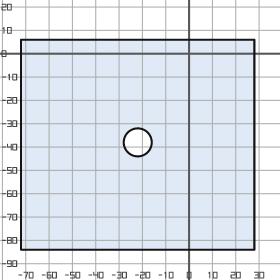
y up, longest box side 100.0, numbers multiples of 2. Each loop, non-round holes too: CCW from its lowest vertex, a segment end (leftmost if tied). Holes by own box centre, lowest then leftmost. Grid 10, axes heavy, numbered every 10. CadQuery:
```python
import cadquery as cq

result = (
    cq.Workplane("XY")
    .moveTo(-72.0, -84.0)
    .lineTo(28.0, -84.0)
    .lineTo(28.0, 6.0)
    .lineTo(-72.0, 6.0)
    .close()
    .moveTo(-22.0, -38.0)
    .circle(6.0)
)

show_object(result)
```